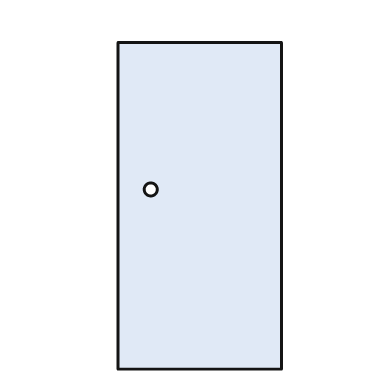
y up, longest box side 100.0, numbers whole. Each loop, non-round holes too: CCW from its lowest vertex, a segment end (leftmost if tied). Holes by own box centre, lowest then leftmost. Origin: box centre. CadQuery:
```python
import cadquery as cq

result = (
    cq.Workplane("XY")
    .moveTo(-25.0, -50.0)
    .lineTo(25.0, -50.0)
    .lineTo(25.0, 50.0)
    .lineTo(-25.0, 50.0)
    .close()
    .moveTo(-15.0, 5.0)
    .circle(2.0)
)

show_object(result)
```